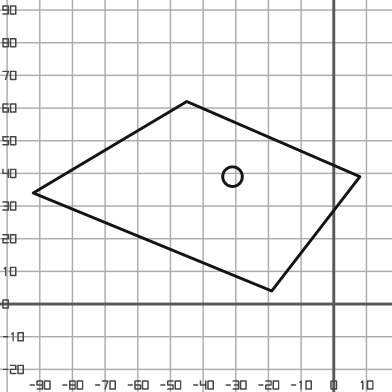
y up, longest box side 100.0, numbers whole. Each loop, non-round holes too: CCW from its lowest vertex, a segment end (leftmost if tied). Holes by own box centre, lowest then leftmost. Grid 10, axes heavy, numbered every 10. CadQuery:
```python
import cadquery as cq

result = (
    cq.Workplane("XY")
    .moveTo(-19.0, 4.0)
    .lineTo(8.0, 39.0)
    .lineTo(-45.0, 62.0)
    .lineTo(-92.0, 34.0)
    .close()
    .moveTo(-31.0, 39.0)
    .circle(3.0)
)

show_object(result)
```